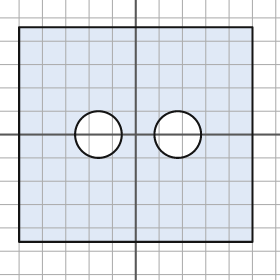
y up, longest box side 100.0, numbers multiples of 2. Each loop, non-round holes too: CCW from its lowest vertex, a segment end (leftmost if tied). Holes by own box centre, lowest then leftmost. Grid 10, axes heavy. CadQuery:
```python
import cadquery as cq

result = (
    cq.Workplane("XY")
    .moveTo(-50.0, -46.0)
    .lineTo(50.0, -46.0)
    .lineTo(50.0, 46.0)
    .lineTo(-50.0, 46.0)
    .close()
    .moveTo(-16.0, 0.0)
    .circle(10.0)
    .moveTo(18.0, 0.0)
    .circle(10.0)
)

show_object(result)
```